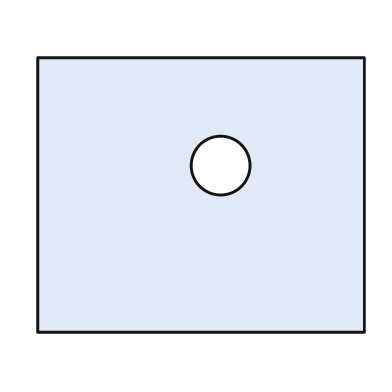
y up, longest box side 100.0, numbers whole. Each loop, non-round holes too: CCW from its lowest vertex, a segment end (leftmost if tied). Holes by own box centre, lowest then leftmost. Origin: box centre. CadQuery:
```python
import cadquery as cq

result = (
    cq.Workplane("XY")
    .moveTo(-50.0, -42.0)
    .lineTo(50.0, -42.0)
    .lineTo(50.0, 42.0)
    .lineTo(-50.0, 42.0)
    .close()
    .moveTo(6.0, 9.0)
    .circle(9.0)
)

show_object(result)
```